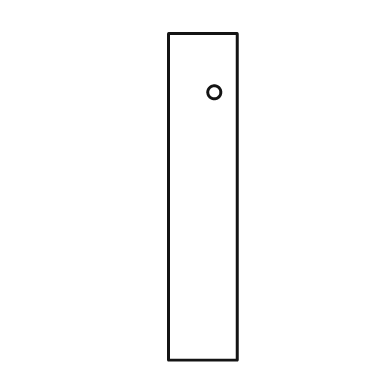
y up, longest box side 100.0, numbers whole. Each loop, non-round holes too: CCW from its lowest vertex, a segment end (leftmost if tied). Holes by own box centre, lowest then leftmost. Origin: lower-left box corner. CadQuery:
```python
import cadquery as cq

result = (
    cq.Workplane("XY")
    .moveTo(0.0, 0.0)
    .lineTo(21.0, 0.0)
    .lineTo(21.0, 100.0)
    .lineTo(0.0, 100.0)
    .close()
    .moveTo(14.0, 82.0)
    .circle(2.0)
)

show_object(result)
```